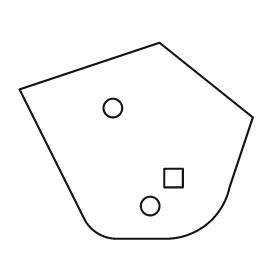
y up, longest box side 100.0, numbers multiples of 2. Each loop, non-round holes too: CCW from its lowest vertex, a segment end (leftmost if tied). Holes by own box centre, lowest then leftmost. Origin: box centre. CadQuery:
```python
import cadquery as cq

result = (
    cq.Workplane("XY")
    .moveTo(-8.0, -42.0)
    .lineTo(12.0, -42.0)
    .threePointArc((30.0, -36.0), (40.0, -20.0))
    .lineTo(50.0, 10.0)
    .lineTo(10.0, 42.0)
    .lineTo(-50.0, 22.0)
    .lineTo(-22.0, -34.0)
    .threePointArc((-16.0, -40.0), (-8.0, -42.0))
    .close()
    .moveTo(6.0, -28.0)
    .circle(4.0)
    .moveTo(12.0, -20.0)
    .lineTo(20.0, -20.0)
    .lineTo(20.0, -12.0)
    .lineTo(12.0, -12.0)
    .close()
    .moveTo(-10.0, 14.0)
    .circle(4.0)
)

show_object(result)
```